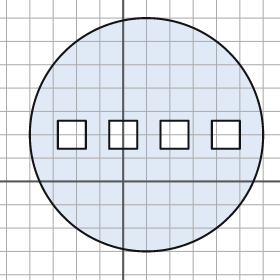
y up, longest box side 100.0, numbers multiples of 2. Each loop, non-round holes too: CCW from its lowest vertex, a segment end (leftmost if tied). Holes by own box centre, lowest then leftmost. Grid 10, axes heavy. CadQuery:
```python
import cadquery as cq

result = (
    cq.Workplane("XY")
    .moveTo(10.0, 20.0)
    .circle(50.0)
    .moveTo(-28.0, 14.0)
    .lineTo(-16.0, 14.0)
    .lineTo(-16.0, 26.0)
    .lineTo(-28.0, 26.0)
    .close()
    .moveTo(-6.0, 14.0)
    .lineTo(6.0, 14.0)
    .lineTo(6.0, 26.0)
    .lineTo(-6.0, 26.0)
    .close()
    .moveTo(16.0, 14.0)
    .lineTo(28.0, 14.0)
    .lineTo(28.0, 26.0)
    .lineTo(16.0, 26.0)
    .close()
    .moveTo(38.0, 14.0)
    .lineTo(50.0, 14.0)
    .lineTo(50.0, 26.0)
    .lineTo(38.0, 26.0)
    .close()
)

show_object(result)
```